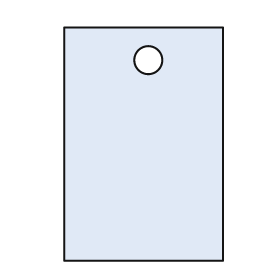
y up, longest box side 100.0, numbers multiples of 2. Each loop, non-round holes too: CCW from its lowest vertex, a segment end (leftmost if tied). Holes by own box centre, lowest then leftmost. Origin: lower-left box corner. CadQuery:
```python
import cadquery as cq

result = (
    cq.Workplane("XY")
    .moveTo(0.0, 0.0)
    .lineTo(68.0, 0.0)
    .lineTo(68.0, 100.0)
    .lineTo(0.0, 100.0)
    .close()
    .moveTo(36.0, 86.0)
    .circle(6.0)
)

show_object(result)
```